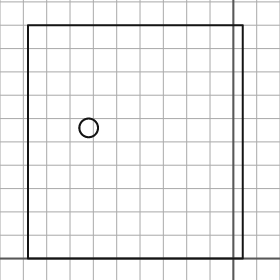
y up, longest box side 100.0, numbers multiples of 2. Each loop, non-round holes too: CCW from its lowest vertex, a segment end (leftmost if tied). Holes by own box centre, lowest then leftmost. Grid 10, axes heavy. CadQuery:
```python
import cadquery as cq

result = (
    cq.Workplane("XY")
    .moveTo(-88.0, 0.0)
    .lineTo(4.0, 0.0)
    .lineTo(4.0, 100.0)
    .lineTo(-88.0, 100.0)
    .close()
    .moveTo(-62.0, 56.0)
    .circle(4.0)
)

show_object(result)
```